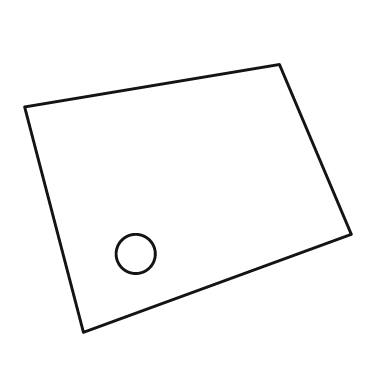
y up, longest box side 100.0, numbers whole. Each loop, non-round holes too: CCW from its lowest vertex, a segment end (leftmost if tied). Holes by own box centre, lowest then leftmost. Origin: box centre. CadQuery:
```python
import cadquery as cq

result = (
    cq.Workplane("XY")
    .moveTo(-32.0, -41.0)
    .lineTo(50.0, -11.0)
    .lineTo(28.0, 41.0)
    .lineTo(-50.0, 28.0)
    .close()
    .moveTo(-16.0, -17.0)
    .circle(6.0)
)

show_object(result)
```